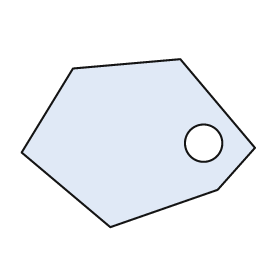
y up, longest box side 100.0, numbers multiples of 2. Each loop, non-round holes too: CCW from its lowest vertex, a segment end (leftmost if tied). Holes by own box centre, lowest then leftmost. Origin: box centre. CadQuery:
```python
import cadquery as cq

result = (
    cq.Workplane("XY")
    .moveTo(-12.0, -36.0)
    .lineTo(34.0, -20.0)
    .lineTo(50.0, -2.0)
    .lineTo(18.0, 36.0)
    .lineTo(-28.0, 32.0)
    .lineTo(-50.0, -4.0)
    .close()
    .moveTo(28.0, 0.0)
    .circle(8.0)
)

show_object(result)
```